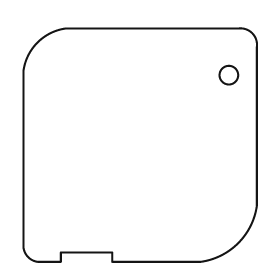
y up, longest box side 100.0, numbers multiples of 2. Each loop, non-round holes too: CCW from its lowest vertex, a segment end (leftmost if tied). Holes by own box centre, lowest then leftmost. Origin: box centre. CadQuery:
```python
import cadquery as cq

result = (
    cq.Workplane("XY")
    .moveTo(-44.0, -50.0)
    .lineTo(-34.0, -50.0)
    .lineTo(-34.0, -46.0)
    .lineTo(-12.0, -46.0)
    .lineTo(-12.0, -50.0)
    .lineTo(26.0, -50.0)
    .threePointArc((42.0, -42.0), (50.0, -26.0))
    .lineTo(50.0, 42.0)
    .threePointArc((48.0, 48.0), (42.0, 50.0))
    .lineTo(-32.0, 50.0)
    .threePointArc((-44.0, 44.0), (-50.0, 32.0))
    .lineTo(-50.0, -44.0)
    .threePointArc((-48.0, -48.0), (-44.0, -50.0))
    .close()
    .moveTo(38.0, 30.0)
    .circle(4.0)
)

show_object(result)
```